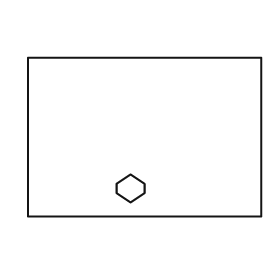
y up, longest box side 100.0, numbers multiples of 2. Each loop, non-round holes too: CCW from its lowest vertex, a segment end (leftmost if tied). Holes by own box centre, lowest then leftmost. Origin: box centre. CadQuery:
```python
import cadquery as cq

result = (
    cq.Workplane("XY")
    .moveTo(-50.0, -34.0)
    .lineTo(50.0, -34.0)
    .lineTo(50.0, 34.0)
    .lineTo(-50.0, 34.0)
    .close()
    .moveTo(-6.0, -28.0)
    .lineTo(0.0, -24.0)
    .lineTo(0.0, -20.0)
    .lineTo(-6.0, -16.0)
    .lineTo(-12.0, -20.0)
    .lineTo(-12.0, -24.0)
    .close()
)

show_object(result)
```